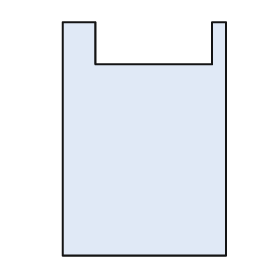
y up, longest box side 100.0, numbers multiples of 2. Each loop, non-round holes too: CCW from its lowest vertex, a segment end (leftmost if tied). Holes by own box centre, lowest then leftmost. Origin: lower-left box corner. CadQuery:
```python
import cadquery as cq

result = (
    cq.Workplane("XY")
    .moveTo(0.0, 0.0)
    .lineTo(70.0, 0.0)
    .lineTo(70.0, 100.0)
    .lineTo(64.0, 100.0)
    .lineTo(64.0, 82.0)
    .lineTo(14.0, 82.0)
    .lineTo(14.0, 100.0)
    .lineTo(0.0, 100.0)
    .close()
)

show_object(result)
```